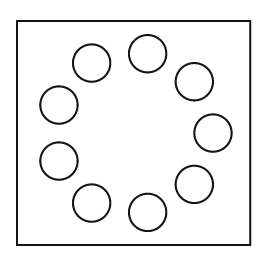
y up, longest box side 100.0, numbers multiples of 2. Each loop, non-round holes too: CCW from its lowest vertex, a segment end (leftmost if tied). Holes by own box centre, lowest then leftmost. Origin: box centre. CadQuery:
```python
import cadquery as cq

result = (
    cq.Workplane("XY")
    .moveTo(-50.0, -48.0)
    .lineTo(50.0, -48.0)
    .lineTo(50.0, 48.0)
    .lineTo(-50.0, 48.0)
    .close()
    .moveTo(6.0, -34.0)
    .circle(8.0)
    .moveTo(-18.0, -30.0)
    .circle(8.0)
    .moveTo(26.0, -22.0)
    .circle(8.0)
    .moveTo(-32.0, -12.0)
    .circle(8.0)
    .moveTo(34.0, 0.0)
    .circle(8.0)
    .moveTo(-32.0, 12.0)
    .circle(8.0)
    .moveTo(26.0, 22.0)
    .circle(8.0)
    .moveTo(-18.0, 30.0)
    .circle(8.0)
    .moveTo(6.0, 34.0)
    .circle(8.0)
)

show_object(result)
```